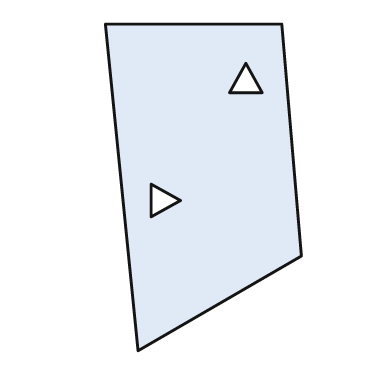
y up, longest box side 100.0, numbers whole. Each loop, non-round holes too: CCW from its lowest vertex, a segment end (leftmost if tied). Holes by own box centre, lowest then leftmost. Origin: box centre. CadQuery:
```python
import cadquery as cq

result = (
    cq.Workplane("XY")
    .moveTo(-20.0, -50.0)
    .lineTo(30.0, -21.0)
    .lineTo(24.0, 50.0)
    .lineTo(-30.0, 50.0)
    .close()
    .moveTo(-16.0, -9.0)
    .lineTo(-7.0, -4.0)
    .lineTo(-16.0, 1.0)
    .close()
    .moveTo(8.0, 29.0)
    .lineTo(18.0, 29.0)
    .lineTo(13.0, 38.0)
    .close()
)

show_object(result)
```